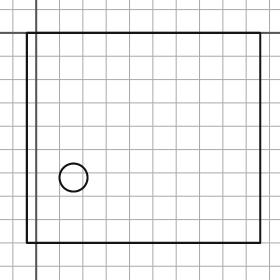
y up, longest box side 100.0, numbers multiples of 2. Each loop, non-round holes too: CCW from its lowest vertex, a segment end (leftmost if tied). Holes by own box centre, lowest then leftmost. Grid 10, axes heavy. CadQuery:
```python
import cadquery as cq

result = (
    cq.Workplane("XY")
    .moveTo(-4.0, -90.0)
    .lineTo(96.0, -90.0)
    .lineTo(96.0, 0.0)
    .lineTo(-4.0, 0.0)
    .close()
    .moveTo(16.0, -62.0)
    .circle(6.0)
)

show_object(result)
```